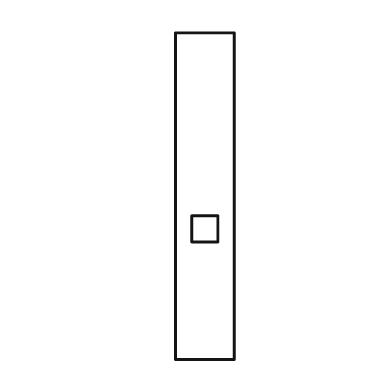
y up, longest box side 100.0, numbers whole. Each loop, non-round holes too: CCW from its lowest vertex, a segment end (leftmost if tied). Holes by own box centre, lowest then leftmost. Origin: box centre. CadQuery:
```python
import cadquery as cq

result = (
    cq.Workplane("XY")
    .moveTo(-9.0, -50.0)
    .lineTo(9.0, -50.0)
    .lineTo(9.0, 50.0)
    .lineTo(-9.0, 50.0)
    .close()
    .moveTo(-4.0, -14.0)
    .lineTo(4.0, -14.0)
    .lineTo(4.0, -6.0)
    .lineTo(-4.0, -6.0)
    .close()
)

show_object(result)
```